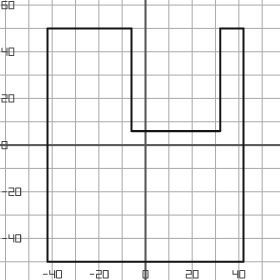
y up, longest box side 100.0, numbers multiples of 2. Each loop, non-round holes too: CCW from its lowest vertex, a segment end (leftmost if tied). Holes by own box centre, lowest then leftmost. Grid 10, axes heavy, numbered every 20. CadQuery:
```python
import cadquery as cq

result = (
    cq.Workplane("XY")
    .moveTo(-42.0, -50.0)
    .lineTo(42.0, -50.0)
    .lineTo(42.0, 50.0)
    .lineTo(32.0, 50.0)
    .lineTo(32.0, 6.0)
    .lineTo(-6.0, 6.0)
    .lineTo(-6.0, 50.0)
    .lineTo(-42.0, 50.0)
    .close()
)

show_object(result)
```